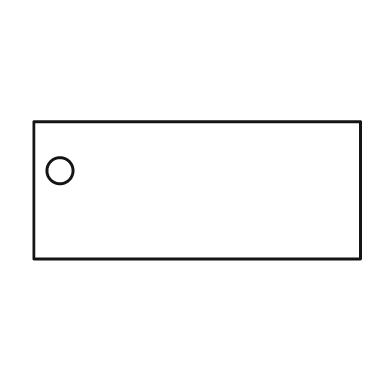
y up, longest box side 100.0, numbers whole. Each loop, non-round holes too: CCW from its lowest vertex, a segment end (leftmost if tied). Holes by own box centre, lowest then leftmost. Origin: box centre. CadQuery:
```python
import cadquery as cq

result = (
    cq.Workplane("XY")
    .moveTo(-50.0, -21.0)
    .lineTo(50.0, -21.0)
    .lineTo(50.0, 21.0)
    .lineTo(-50.0, 21.0)
    .close()
    .moveTo(-42.0, 6.0)
    .circle(4.0)
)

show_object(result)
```